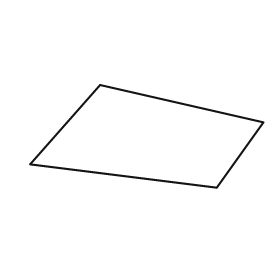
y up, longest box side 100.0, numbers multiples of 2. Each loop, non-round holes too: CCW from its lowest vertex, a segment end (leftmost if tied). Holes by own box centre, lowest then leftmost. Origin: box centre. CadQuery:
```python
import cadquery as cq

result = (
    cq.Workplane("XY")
    .moveTo(30.0, -22.0)
    .lineTo(50.0, 6.0)
    .lineTo(-20.0, 22.0)
    .lineTo(-50.0, -12.0)
    .close()
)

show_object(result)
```